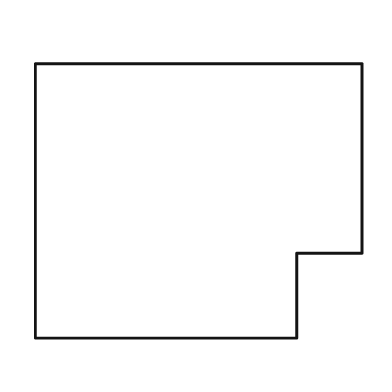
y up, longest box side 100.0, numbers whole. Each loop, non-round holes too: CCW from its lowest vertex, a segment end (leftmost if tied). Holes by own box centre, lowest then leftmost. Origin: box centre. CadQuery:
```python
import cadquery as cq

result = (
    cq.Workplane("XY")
    .moveTo(-50.0, -42.0)
    .lineTo(30.0, -42.0)
    .lineTo(30.0, -16.0)
    .lineTo(50.0, -16.0)
    .lineTo(50.0, 42.0)
    .lineTo(-50.0, 42.0)
    .close()
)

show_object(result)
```